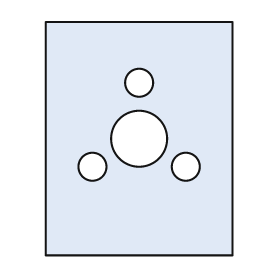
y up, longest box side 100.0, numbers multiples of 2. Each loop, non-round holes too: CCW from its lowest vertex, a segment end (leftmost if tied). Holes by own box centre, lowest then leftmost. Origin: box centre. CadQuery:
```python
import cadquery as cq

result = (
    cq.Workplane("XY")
    .moveTo(-40.0, -50.0)
    .lineTo(40.0, -50.0)
    .lineTo(40.0, 50.0)
    .lineTo(-40.0, 50.0)
    .close()
    .moveTo(-20.0, -12.0)
    .circle(6.0)
    .moveTo(20.0, -12.0)
    .circle(6.0)
    .moveTo(0.0, 0.0)
    .circle(12.0)
    .moveTo(0.0, 24.0)
    .circle(6.0)
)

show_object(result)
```